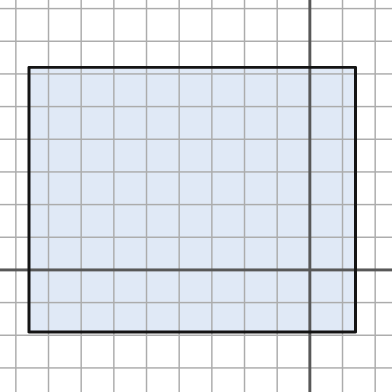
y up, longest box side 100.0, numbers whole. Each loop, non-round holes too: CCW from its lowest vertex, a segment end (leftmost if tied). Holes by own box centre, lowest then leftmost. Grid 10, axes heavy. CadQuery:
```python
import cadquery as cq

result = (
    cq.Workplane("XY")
    .moveTo(-86.0, -19.0)
    .lineTo(14.0, -19.0)
    .lineTo(14.0, 62.0)
    .lineTo(-86.0, 62.0)
    .close()
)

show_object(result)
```